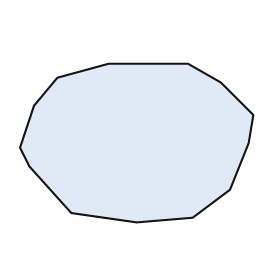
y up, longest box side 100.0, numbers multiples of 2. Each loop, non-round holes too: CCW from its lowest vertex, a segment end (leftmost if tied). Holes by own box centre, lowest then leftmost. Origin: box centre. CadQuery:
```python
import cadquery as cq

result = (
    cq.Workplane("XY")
    .moveTo(0.0, -34.0)
    .lineTo(24.0, -32.0)
    .lineTo(40.0, -20.0)
    .lineTo(48.0, 0.0)
    .lineTo(50.0, 12.0)
    .lineTo(36.0, 26.0)
    .lineTo(22.0, 34.0)
    .lineTo(-12.0, 34.0)
    .lineTo(-34.0, 28.0)
    .lineTo(-44.0, 16.0)
    .lineTo(-50.0, -2.0)
    .lineTo(-46.0, -10.0)
    .lineTo(-28.0, -30.0)
    .close()
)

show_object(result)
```